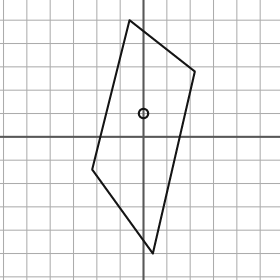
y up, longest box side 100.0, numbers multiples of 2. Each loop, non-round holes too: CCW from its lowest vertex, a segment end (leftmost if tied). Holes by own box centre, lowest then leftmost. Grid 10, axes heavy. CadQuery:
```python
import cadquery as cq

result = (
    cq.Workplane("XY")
    .moveTo(4.0, -50.0)
    .lineTo(22.0, 28.0)
    .lineTo(-6.0, 50.0)
    .lineTo(-22.0, -14.0)
    .close()
    .moveTo(0.0, 10.0)
    .circle(2.0)
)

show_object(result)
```